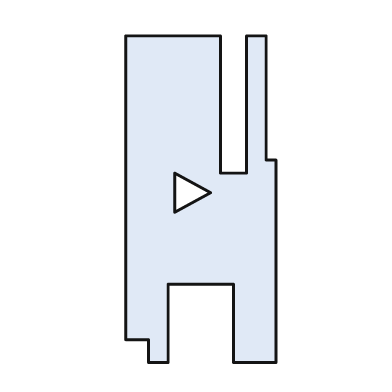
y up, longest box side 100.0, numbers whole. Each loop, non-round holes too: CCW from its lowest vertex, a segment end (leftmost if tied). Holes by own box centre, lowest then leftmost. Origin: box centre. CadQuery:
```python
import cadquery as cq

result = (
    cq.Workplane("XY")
    .moveTo(-16.0, -50.0)
    .lineTo(-10.0, -50.0)
    .lineTo(-10.0, -26.0)
    .lineTo(10.0, -26.0)
    .lineTo(10.0, -50.0)
    .lineTo(23.0, -50.0)
    .lineTo(23.0, 12.0)
    .lineTo(20.0, 12.0)
    .lineTo(20.0, 50.0)
    .lineTo(14.0, 50.0)
    .lineTo(14.0, 8.0)
    .lineTo(6.0, 8.0)
    .lineTo(6.0, 50.0)
    .lineTo(-23.0, 50.0)
    .lineTo(-23.0, -43.0)
    .lineTo(-16.0, -43.0)
    .close()
    .moveTo(-8.0, -4.0)
    .lineTo(3.0, 2.0)
    .lineTo(-8.0, 8.0)
    .close()
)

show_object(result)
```